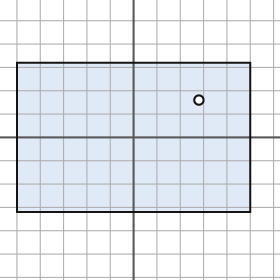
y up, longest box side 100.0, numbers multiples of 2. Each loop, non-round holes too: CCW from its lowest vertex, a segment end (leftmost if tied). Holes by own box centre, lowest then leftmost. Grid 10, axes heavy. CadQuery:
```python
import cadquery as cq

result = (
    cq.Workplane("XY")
    .moveTo(-50.0, -32.0)
    .lineTo(50.0, -32.0)
    .lineTo(50.0, 32.0)
    .lineTo(-50.0, 32.0)
    .close()
    .moveTo(28.0, 16.0)
    .circle(2.0)
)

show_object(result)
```